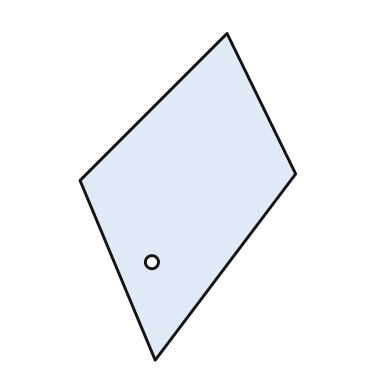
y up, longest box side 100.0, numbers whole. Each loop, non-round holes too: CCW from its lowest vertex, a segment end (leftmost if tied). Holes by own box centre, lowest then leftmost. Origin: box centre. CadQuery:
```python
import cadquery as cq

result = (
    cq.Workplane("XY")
    .moveTo(-10.0, -50.0)
    .lineTo(33.0, 7.0)
    .lineTo(12.0, 50.0)
    .lineTo(-33.0, 5.0)
    .close()
    .moveTo(-11.0, -20.0)
    .circle(2.0)
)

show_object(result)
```